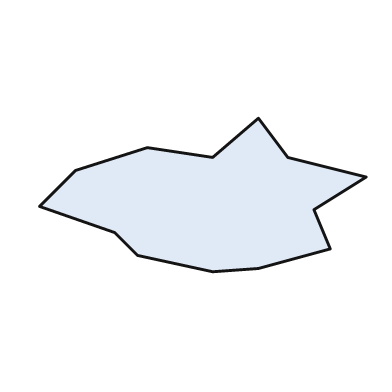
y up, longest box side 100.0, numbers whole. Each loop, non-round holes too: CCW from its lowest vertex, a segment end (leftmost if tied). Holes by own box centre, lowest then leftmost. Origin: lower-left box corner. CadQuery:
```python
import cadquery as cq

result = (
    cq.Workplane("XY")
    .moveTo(53.0, 0.0)
    .lineTo(67.0, 1.0)
    .lineTo(89.0, 7.0)
    .lineTo(84.0, 19.0)
    .lineTo(100.0, 29.0)
    .lineTo(76.0, 35.0)
    .lineTo(67.0, 47.0)
    .lineTo(53.0, 35.0)
    .lineTo(33.0, 38.0)
    .lineTo(11.0, 31.0)
    .lineTo(0.0, 20.0)
    .lineTo(23.0, 12.0)
    .lineTo(30.0, 5.0)
    .close()
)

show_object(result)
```